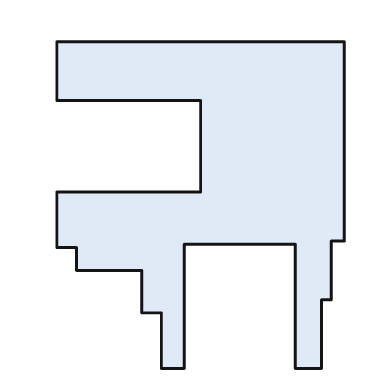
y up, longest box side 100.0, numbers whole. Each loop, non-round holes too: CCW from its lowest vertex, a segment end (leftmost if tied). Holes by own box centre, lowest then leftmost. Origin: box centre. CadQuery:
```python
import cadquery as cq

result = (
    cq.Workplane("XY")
    .moveTo(-12.0, -50.0)
    .lineTo(-5.0, -50.0)
    .lineTo(-5.0, -12.0)
    .lineTo(29.0, -12.0)
    .lineTo(29.0, -50.0)
    .lineTo(37.0, -50.0)
    .lineTo(37.0, -29.0)
    .lineTo(40.0, -29.0)
    .lineTo(40.0, -11.0)
    .lineTo(44.0, -11.0)
    .lineTo(44.0, 50.0)
    .lineTo(-44.0, 50.0)
    .lineTo(-44.0, 32.0)
    .lineTo(0.0, 32.0)
    .lineTo(0.0, 4.0)
    .lineTo(-44.0, 4.0)
    .lineTo(-44.0, -13.0)
    .lineTo(-38.0, -13.0)
    .lineTo(-38.0, -20.0)
    .lineTo(-18.0, -20.0)
    .lineTo(-18.0, -33.0)
    .lineTo(-12.0, -33.0)
    .close()
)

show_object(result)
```